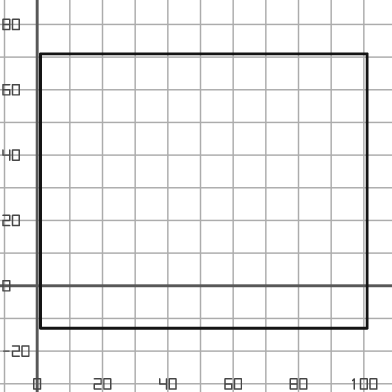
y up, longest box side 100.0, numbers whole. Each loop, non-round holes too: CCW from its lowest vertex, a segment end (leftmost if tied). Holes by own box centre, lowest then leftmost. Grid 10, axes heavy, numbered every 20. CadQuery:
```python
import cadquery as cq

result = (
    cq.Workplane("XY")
    .moveTo(1.0, -13.0)
    .lineTo(101.0, -13.0)
    .lineTo(101.0, 71.0)
    .lineTo(1.0, 71.0)
    .close()
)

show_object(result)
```